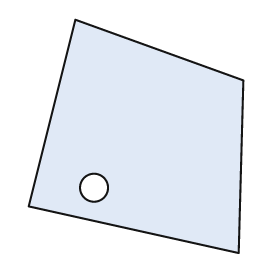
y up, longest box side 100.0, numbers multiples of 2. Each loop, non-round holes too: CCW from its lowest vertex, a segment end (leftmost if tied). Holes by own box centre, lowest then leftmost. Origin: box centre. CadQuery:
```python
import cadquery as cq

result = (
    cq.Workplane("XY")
    .moveTo(44.0, -50.0)
    .lineTo(46.0, 24.0)
    .lineTo(-26.0, 50.0)
    .lineTo(-46.0, -30.0)
    .close()
    .moveTo(-18.0, -22.0)
    .circle(6.0)
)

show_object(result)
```